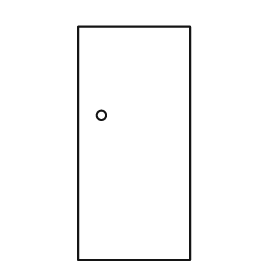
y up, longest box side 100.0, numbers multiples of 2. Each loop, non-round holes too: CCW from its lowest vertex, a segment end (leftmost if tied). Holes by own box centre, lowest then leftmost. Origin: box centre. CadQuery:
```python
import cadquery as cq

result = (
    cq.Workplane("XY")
    .moveTo(-24.0, -50.0)
    .lineTo(24.0, -50.0)
    .lineTo(24.0, 50.0)
    .lineTo(-24.0, 50.0)
    .close()
    .moveTo(-14.0, 12.0)
    .circle(2.0)
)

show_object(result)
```